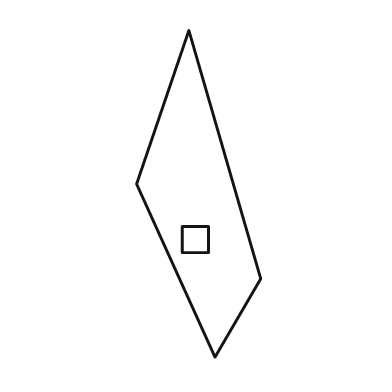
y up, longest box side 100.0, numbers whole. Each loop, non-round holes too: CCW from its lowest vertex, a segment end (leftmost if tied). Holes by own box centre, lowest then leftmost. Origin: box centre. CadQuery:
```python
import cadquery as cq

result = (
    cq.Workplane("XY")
    .moveTo(5.0, -50.0)
    .lineTo(19.0, -26.0)
    .lineTo(-3.0, 50.0)
    .lineTo(-19.0, 3.0)
    .close()
    .moveTo(-5.0, -18.0)
    .lineTo(3.0, -18.0)
    .lineTo(3.0, -10.0)
    .lineTo(-5.0, -10.0)
    .close()
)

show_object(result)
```